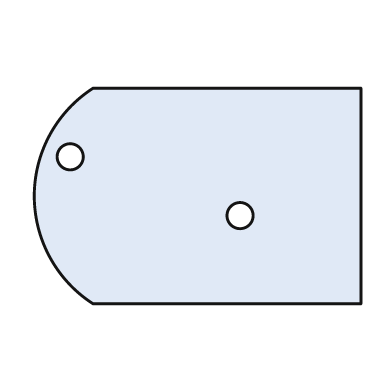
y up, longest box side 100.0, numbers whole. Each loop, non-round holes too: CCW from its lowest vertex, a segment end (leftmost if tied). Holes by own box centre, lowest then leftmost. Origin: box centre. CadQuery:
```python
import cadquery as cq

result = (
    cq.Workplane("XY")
    .moveTo(-32.0, -33.0)
    .lineTo(50.0, -33.0)
    .lineTo(50.0, 33.0)
    .lineTo(-32.0, 33.0)
    .threePointArc((-50.0, 0.0), (-32.0, -33.0))
    .close()
    .moveTo(13.0, -6.0)
    .circle(4.0)
    .moveTo(-39.0, 12.0)
    .circle(4.0)
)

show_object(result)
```